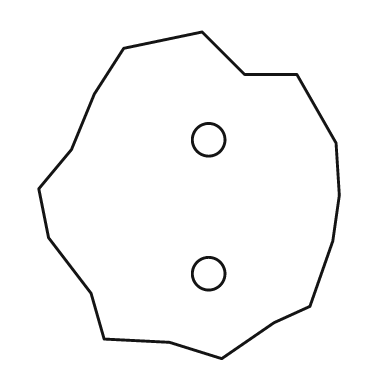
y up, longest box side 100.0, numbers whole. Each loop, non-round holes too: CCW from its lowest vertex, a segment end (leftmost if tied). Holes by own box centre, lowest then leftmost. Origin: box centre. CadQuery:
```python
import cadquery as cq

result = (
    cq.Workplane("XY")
    .moveTo(10.0, -50.0)
    .lineTo(26.0, -39.0)
    .lineTo(37.0, -34.0)
    .lineTo(44.0, -14.0)
    .lineTo(46.0, 0.0)
    .lineTo(45.0, 16.0)
    .lineTo(33.0, 37.0)
    .lineTo(17.0, 37.0)
    .lineTo(4.0, 50.0)
    .lineTo(-20.0, 45.0)
    .lineTo(-29.0, 31.0)
    .lineTo(-36.0, 14.0)
    .lineTo(-46.0, 2.0)
    .lineTo(-43.0, -13.0)
    .lineTo(-30.0, -30.0)
    .lineTo(-26.0, -44.0)
    .lineTo(-6.0, -45.0)
    .close()
    .moveTo(6.0, -24.0)
    .circle(5.0)
    .moveTo(6.0, 17.0)
    .circle(5.0)
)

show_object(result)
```